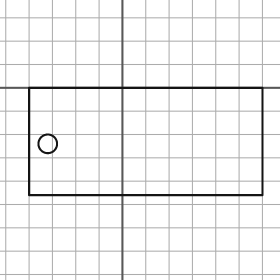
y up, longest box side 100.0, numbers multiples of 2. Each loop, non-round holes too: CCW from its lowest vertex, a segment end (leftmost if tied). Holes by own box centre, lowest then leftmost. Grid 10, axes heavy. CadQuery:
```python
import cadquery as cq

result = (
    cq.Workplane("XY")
    .moveTo(-40.0, -46.0)
    .lineTo(60.0, -46.0)
    .lineTo(60.0, 0.0)
    .lineTo(-40.0, 0.0)
    .close()
    .moveTo(-32.0, -24.0)
    .circle(4.0)
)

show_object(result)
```